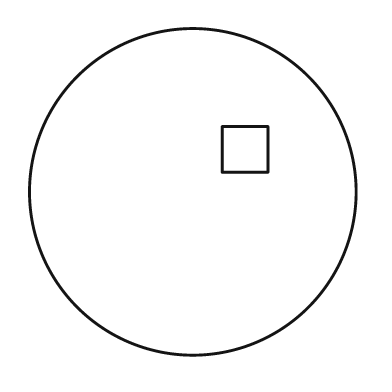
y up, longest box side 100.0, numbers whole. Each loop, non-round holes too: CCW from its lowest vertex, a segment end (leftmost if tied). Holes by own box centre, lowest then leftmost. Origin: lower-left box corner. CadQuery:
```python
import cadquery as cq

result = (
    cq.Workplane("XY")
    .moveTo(50.0, 50.0)
    .circle(50.0)
    .moveTo(59.0, 56.0)
    .lineTo(73.0, 56.0)
    .lineTo(73.0, 70.0)
    .lineTo(59.0, 70.0)
    .close()
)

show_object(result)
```